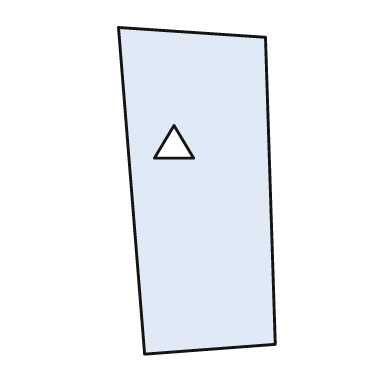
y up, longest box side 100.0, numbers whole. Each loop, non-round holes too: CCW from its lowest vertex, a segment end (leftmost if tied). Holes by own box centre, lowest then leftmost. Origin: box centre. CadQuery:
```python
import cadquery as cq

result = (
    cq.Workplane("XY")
    .moveTo(-16.0, -50.0)
    .lineTo(24.0, -47.0)
    .lineTo(21.0, 47.0)
    .lineTo(-24.0, 50.0)
    .close()
    .moveTo(-13.0, 10.0)
    .lineTo(-1.0, 10.0)
    .lineTo(-7.0, 20.0)
    .close()
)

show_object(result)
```